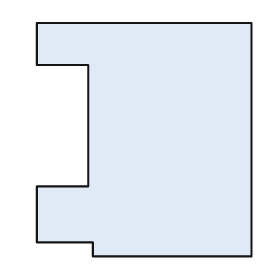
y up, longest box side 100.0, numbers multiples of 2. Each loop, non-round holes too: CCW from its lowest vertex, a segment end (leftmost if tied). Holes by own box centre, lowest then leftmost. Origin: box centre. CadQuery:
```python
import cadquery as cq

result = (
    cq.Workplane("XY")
    .moveTo(-22.0, -50.0)
    .lineTo(46.0, -50.0)
    .lineTo(46.0, 50.0)
    .lineTo(-46.0, 50.0)
    .lineTo(-46.0, 32.0)
    .lineTo(-24.0, 32.0)
    .lineTo(-24.0, -20.0)
    .lineTo(-46.0, -20.0)
    .lineTo(-46.0, -44.0)
    .lineTo(-22.0, -44.0)
    .close()
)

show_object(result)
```